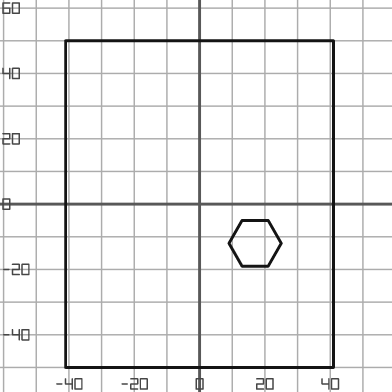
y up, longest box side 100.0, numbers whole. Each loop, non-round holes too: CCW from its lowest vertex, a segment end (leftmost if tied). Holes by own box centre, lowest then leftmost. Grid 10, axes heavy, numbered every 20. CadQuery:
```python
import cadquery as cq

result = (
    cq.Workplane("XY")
    .moveTo(-41.0, -50.0)
    .lineTo(41.0, -50.0)
    .lineTo(41.0, 50.0)
    .lineTo(-41.0, 50.0)
    .close()
    .moveTo(13.0, -19.0)
    .lineTo(21.0, -19.0)
    .lineTo(25.0, -12.0)
    .lineTo(21.0, -5.0)
    .lineTo(13.0, -5.0)
    .lineTo(9.0, -12.0)
    .close()
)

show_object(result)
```